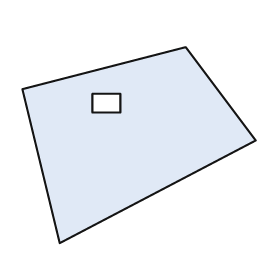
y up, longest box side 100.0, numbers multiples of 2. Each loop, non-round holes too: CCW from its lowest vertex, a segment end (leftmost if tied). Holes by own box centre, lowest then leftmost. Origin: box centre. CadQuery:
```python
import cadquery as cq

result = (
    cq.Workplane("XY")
    .moveTo(-34.0, -42.0)
    .lineTo(50.0, 2.0)
    .lineTo(20.0, 42.0)
    .lineTo(-50.0, 24.0)
    .close()
    .moveTo(-20.0, 14.0)
    .lineTo(-8.0, 14.0)
    .lineTo(-8.0, 22.0)
    .lineTo(-20.0, 22.0)
    .close()
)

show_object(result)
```